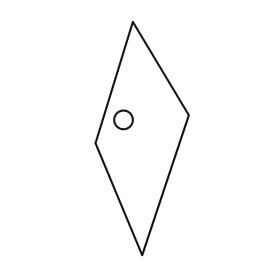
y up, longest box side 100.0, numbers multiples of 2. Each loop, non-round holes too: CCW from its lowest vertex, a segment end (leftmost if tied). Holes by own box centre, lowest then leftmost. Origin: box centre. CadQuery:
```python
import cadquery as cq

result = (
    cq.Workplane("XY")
    .moveTo(0.0, -50.0)
    .lineTo(20.0, 10.0)
    .lineTo(-4.0, 50.0)
    .lineTo(-20.0, -2.0)
    .close()
    .moveTo(-8.0, 8.0)
    .circle(4.0)
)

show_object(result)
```